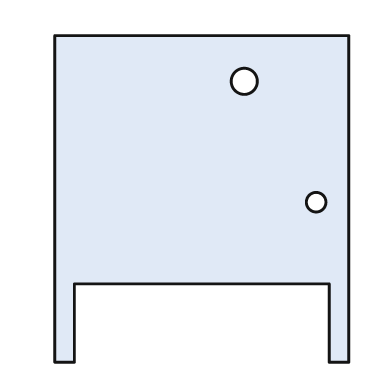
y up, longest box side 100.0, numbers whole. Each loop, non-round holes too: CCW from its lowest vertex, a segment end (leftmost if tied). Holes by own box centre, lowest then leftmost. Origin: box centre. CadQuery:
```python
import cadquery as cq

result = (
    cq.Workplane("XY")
    .moveTo(-45.0, -50.0)
    .lineTo(-39.0, -50.0)
    .lineTo(-39.0, -26.0)
    .lineTo(39.0, -26.0)
    .lineTo(39.0, -50.0)
    .lineTo(45.0, -50.0)
    .lineTo(45.0, 50.0)
    .lineTo(-45.0, 50.0)
    .close()
    .moveTo(35.0, -1.0)
    .circle(3.0)
    .moveTo(13.0, 36.0)
    .circle(4.0)
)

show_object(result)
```